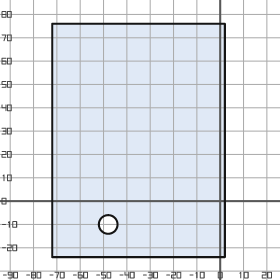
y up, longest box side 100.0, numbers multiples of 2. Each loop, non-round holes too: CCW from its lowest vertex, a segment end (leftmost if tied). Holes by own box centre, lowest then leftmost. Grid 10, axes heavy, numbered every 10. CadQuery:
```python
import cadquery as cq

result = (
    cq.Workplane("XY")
    .moveTo(-72.0, -24.0)
    .lineTo(2.0, -24.0)
    .lineTo(2.0, 76.0)
    .lineTo(-72.0, 76.0)
    .close()
    .moveTo(-48.0, -10.0)
    .circle(4.0)
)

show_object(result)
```